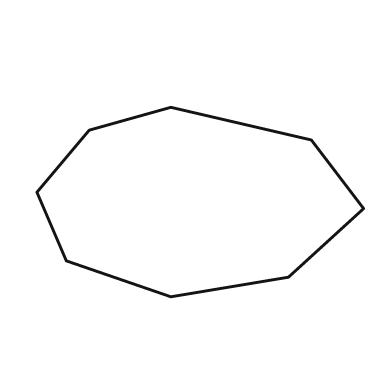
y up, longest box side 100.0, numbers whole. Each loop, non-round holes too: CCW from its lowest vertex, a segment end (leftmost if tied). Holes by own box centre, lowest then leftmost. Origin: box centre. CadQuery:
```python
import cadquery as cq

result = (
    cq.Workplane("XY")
    .moveTo(-9.0, -29.0)
    .lineTo(27.0, -23.0)
    .lineTo(50.0, -2.0)
    .lineTo(34.0, 19.0)
    .lineTo(-9.0, 29.0)
    .lineTo(-34.0, 22.0)
    .lineTo(-50.0, 3.0)
    .lineTo(-41.0, -18.0)
    .close()
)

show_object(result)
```